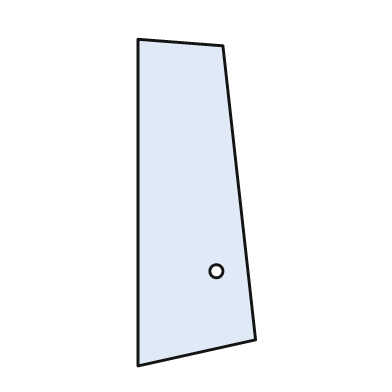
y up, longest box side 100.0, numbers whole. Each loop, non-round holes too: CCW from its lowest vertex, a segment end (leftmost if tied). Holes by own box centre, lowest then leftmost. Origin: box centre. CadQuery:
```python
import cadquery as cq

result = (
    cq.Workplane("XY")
    .moveTo(-18.0, -50.0)
    .lineTo(18.0, -42.0)
    .lineTo(8.0, 48.0)
    .lineTo(-18.0, 50.0)
    .close()
    .moveTo(6.0, -21.0)
    .circle(2.0)
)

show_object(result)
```